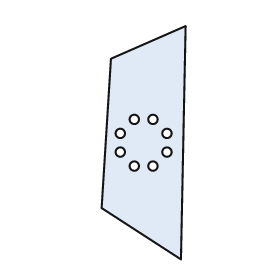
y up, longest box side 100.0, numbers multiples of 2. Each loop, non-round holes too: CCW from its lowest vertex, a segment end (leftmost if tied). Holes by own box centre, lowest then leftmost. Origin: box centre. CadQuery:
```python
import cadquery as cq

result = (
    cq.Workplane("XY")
    .moveTo(16.0, -50.0)
    .lineTo(18.0, 50.0)
    .lineTo(-14.0, 36.0)
    .lineTo(-18.0, -28.0)
    .close()
    .moveTo(-4.0, -10.0)
    .circle(2.0)
    .moveTo(4.0, -10.0)
    .circle(2.0)
    .moveTo(-10.0, -4.0)
    .circle(2.0)
    .moveTo(10.0, -4.0)
    .circle(2.0)
    .moveTo(-10.0, 4.0)
    .circle(2.0)
    .moveTo(10.0, 4.0)
    .circle(2.0)
    .moveTo(-4.0, 10.0)
    .circle(2.0)
    .moveTo(4.0, 10.0)
    .circle(2.0)
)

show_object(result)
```